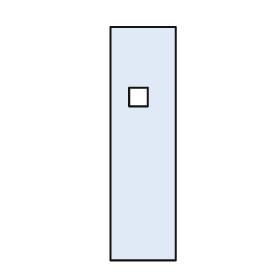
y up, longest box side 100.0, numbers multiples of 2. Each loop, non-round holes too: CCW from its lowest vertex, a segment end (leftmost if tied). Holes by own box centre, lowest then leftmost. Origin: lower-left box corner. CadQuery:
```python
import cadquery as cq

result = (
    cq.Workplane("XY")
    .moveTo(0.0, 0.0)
    .lineTo(28.0, 0.0)
    .lineTo(28.0, 100.0)
    .lineTo(0.0, 100.0)
    .close()
    .moveTo(8.0, 66.0)
    .lineTo(16.0, 66.0)
    .lineTo(16.0, 74.0)
    .lineTo(8.0, 74.0)
    .close()
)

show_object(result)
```